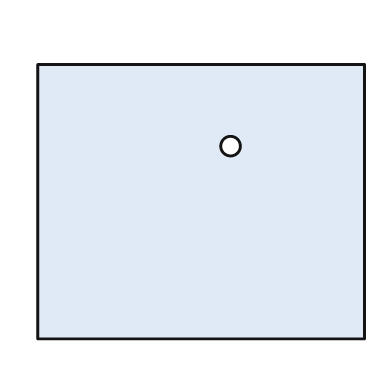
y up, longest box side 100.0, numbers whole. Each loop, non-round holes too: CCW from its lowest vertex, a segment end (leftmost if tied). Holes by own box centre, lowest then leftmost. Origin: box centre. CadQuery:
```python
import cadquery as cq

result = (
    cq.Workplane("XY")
    .moveTo(-50.0, -42.0)
    .lineTo(50.0, -42.0)
    .lineTo(50.0, 42.0)
    .lineTo(-50.0, 42.0)
    .close()
    .moveTo(9.0, 17.0)
    .circle(3.0)
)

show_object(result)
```